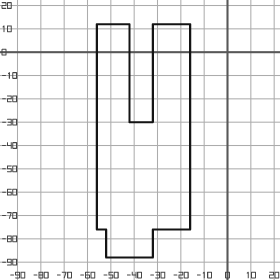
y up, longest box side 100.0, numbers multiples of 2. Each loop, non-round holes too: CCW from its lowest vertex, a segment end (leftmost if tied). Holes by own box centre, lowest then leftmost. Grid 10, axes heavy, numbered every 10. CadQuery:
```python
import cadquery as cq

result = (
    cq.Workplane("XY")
    .moveTo(-52.0, -88.0)
    .lineTo(-32.0, -88.0)
    .lineTo(-32.0, -76.0)
    .lineTo(-16.0, -76.0)
    .lineTo(-16.0, 12.0)
    .lineTo(-32.0, 12.0)
    .lineTo(-32.0, -30.0)
    .lineTo(-42.0, -30.0)
    .lineTo(-42.0, 12.0)
    .lineTo(-56.0, 12.0)
    .lineTo(-56.0, -76.0)
    .lineTo(-52.0, -76.0)
    .close()
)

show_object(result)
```